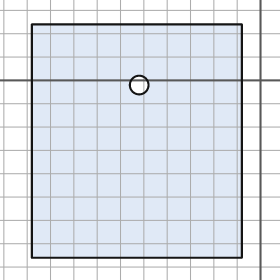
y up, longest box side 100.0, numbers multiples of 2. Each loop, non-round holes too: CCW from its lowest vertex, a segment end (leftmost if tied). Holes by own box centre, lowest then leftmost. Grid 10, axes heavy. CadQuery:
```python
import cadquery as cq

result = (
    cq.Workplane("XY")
    .moveTo(-98.0, -76.0)
    .lineTo(-8.0, -76.0)
    .lineTo(-8.0, 24.0)
    .lineTo(-98.0, 24.0)
    .close()
    .moveTo(-52.0, -2.0)
    .circle(4.0)
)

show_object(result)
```